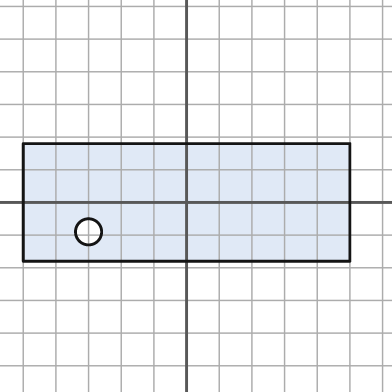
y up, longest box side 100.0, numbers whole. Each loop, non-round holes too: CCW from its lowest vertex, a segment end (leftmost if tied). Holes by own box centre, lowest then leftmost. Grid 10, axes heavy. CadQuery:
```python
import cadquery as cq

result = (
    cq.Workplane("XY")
    .moveTo(-50.0, -18.0)
    .lineTo(50.0, -18.0)
    .lineTo(50.0, 18.0)
    .lineTo(-50.0, 18.0)
    .close()
    .moveTo(-30.0, -9.0)
    .circle(4.0)
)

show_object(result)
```